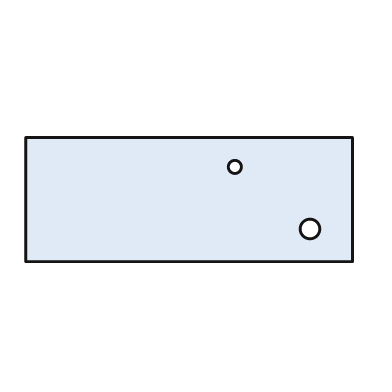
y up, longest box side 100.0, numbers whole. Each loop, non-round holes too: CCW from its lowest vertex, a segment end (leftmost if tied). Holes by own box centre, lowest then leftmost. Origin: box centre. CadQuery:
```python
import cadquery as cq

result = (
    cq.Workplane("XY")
    .moveTo(-50.0, -19.0)
    .lineTo(50.0, -19.0)
    .lineTo(50.0, 19.0)
    .lineTo(-50.0, 19.0)
    .close()
    .moveTo(37.0, -9.0)
    .circle(3.0)
    .moveTo(14.0, 10.0)
    .circle(2.0)
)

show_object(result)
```